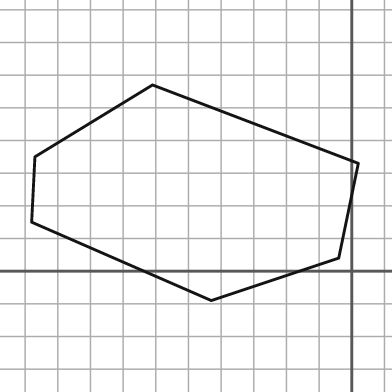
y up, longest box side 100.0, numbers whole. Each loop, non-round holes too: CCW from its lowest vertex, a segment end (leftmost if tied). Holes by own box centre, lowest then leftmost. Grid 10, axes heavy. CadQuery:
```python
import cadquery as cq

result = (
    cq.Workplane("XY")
    .moveTo(-43.0, -9.0)
    .lineTo(-4.0, 4.0)
    .lineTo(2.0, 33.0)
    .lineTo(-61.0, 57.0)
    .lineTo(-97.0, 35.0)
    .lineTo(-98.0, 15.0)
    .close()
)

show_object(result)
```